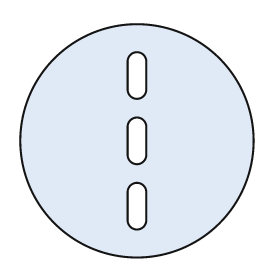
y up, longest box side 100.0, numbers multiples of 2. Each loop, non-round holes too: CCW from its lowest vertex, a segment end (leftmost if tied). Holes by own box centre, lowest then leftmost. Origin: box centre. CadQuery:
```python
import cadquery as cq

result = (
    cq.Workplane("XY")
    .moveTo(0.0, 0.0)
    .circle(50.0)
    .moveTo(-4.0, -34.0)
    .threePointArc((0.0, -38.0), (4.0, -34.0))
    .lineTo(4.0, -22.0)
    .threePointArc((0.0, -18.0), (-4.0, -22.0))
    .close()
    .moveTo(-4.0, -6.0)
    .threePointArc((0.0, -10.0), (4.0, -6.0))
    .lineTo(4.0, 6.0)
    .threePointArc((0.0, 10.0), (-4.0, 6.0))
    .close()
    .moveTo(-4.0, 22.0)
    .threePointArc((0.0, 18.0), (4.0, 22.0))
    .lineTo(4.0, 34.0)
    .threePointArc((0.0, 38.0), (-4.0, 34.0))
    .close()
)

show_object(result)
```